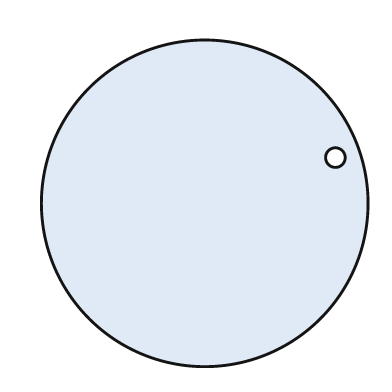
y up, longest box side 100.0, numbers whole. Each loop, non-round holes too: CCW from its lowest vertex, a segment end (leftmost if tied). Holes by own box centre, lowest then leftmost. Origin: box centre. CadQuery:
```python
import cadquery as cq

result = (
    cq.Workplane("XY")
    .moveTo(0.0, 0.0)
    .circle(50.0)
    .moveTo(40.0, 14.0)
    .circle(3.0)
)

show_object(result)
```